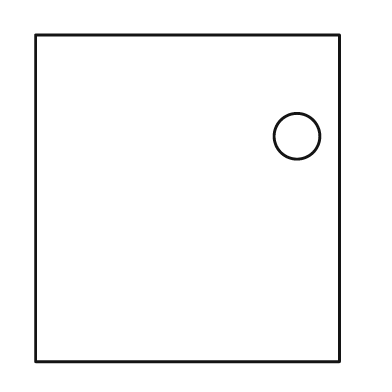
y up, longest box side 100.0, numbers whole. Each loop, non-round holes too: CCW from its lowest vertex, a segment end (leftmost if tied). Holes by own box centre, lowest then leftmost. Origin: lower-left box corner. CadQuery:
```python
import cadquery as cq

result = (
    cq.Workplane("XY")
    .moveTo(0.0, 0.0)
    .lineTo(93.0, 0.0)
    .lineTo(93.0, 100.0)
    .lineTo(0.0, 100.0)
    .close()
    .moveTo(80.0, 69.0)
    .circle(7.0)
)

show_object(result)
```